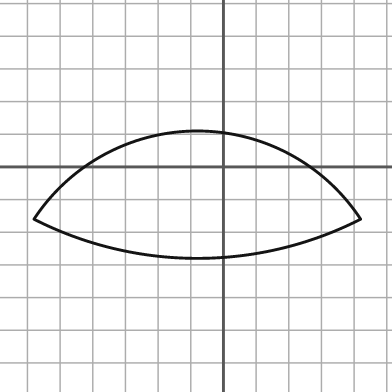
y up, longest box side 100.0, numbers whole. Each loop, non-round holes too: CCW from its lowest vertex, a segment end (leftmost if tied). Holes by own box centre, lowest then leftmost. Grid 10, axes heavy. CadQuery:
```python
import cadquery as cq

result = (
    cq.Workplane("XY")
    .moveTo(-58.0, -16.0)
    .threePointArc((-8.0, -28.0), (42.0, -16.0))
    .threePointArc((-8.0, 11.0), (-58.0, -16.0))
    .close()
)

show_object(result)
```